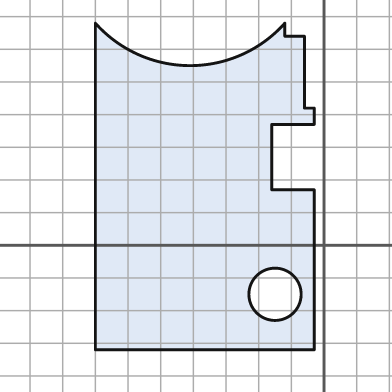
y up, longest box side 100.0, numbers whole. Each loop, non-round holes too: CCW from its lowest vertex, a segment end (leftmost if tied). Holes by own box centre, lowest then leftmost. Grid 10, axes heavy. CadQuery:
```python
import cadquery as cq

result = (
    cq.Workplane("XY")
    .moveTo(-70.0, -32.0)
    .lineTo(-3.0, -32.0)
    .lineTo(-3.0, 17.0)
    .lineTo(-16.0, 17.0)
    .lineTo(-16.0, 37.0)
    .lineTo(-3.0, 37.0)
    .lineTo(-3.0, 42.0)
    .lineTo(-6.0, 42.0)
    .lineTo(-6.0, 64.0)
    .lineTo(-12.0, 64.0)
    .lineTo(-12.0, 68.0)
    .threePointArc((-41.0, 55.0), (-70.0, 68.0))
    .close()
    .moveTo(-15.0, -15.0)
    .circle(8.0)
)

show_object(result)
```